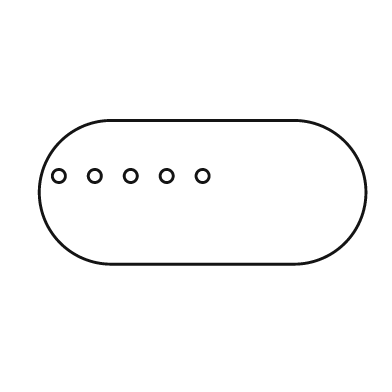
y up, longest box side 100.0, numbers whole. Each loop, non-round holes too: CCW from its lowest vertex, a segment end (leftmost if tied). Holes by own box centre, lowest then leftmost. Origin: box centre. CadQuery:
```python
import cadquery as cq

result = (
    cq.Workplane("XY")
    .moveTo(-28.0, -22.0)
    .lineTo(28.0, -22.0)
    .threePointArc((50.0, 0.0), (28.0, 22.0))
    .lineTo(-28.0, 22.0)
    .threePointArc((-50.0, 0.0), (-28.0, -22.0))
    .close()
    .moveTo(-44.0, 5.0)
    .circle(2.0)
    .moveTo(-33.0, 5.0)
    .circle(2.0)
    .moveTo(-22.0, 5.0)
    .circle(2.0)
    .moveTo(-11.0, 5.0)
    .circle(2.0)
    .moveTo(0.0, 5.0)
    .circle(2.0)
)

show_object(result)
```